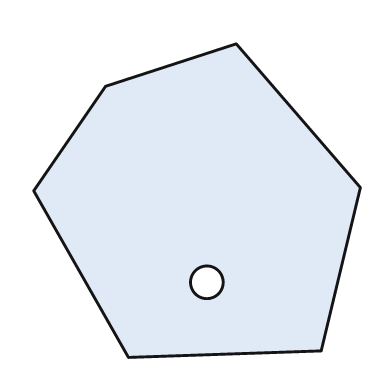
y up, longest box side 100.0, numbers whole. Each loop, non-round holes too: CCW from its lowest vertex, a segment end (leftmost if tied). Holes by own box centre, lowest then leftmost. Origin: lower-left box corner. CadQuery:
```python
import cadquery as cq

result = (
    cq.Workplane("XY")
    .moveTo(29.0, 0.0)
    .lineTo(88.0, 2.0)
    .lineTo(100.0, 52.0)
    .lineTo(62.0, 96.0)
    .lineTo(22.0, 83.0)
    .lineTo(0.0, 51.0)
    .close()
    .moveTo(53.0, 23.0)
    .circle(5.0)
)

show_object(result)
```